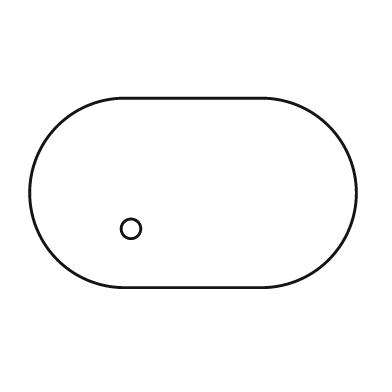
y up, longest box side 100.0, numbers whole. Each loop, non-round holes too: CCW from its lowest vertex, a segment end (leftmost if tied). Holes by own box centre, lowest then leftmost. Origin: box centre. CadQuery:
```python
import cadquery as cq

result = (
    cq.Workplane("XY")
    .moveTo(-21.0, -29.0)
    .lineTo(21.0, -29.0)
    .threePointArc((50.0, 0.0), (21.0, 29.0))
    .lineTo(-21.0, 29.0)
    .threePointArc((-50.0, 0.0), (-21.0, -29.0))
    .close()
    .moveTo(-19.0, -11.0)
    .circle(3.0)
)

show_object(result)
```